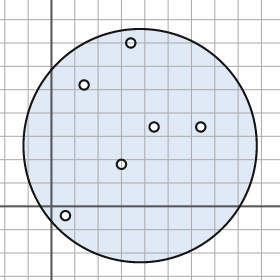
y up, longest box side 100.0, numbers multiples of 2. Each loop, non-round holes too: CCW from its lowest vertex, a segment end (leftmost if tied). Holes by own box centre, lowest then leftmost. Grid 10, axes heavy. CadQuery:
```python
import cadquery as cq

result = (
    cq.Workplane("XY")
    .moveTo(38.0, 26.0)
    .circle(50.0)
    .moveTo(6.0, -4.0)
    .circle(2.0)
    .moveTo(30.0, 18.0)
    .circle(2.0)
    .moveTo(44.0, 34.0)
    .circle(2.0)
    .moveTo(64.0, 34.0)
    .circle(2.0)
    .moveTo(14.0, 52.0)
    .circle(2.0)
    .moveTo(34.0, 70.0)
    .circle(2.0)
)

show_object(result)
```